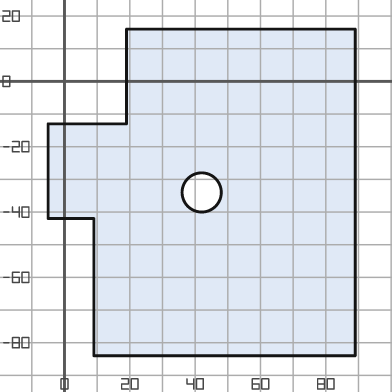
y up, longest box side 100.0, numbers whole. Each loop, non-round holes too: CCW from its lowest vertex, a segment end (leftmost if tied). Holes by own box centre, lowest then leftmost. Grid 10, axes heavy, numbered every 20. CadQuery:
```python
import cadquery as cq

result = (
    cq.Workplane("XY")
    .moveTo(9.0, -84.0)
    .lineTo(89.0, -84.0)
    .lineTo(89.0, 16.0)
    .lineTo(19.0, 16.0)
    .lineTo(19.0, -13.0)
    .lineTo(-5.0, -13.0)
    .lineTo(-5.0, -42.0)
    .lineTo(9.0, -42.0)
    .close()
    .moveTo(42.0, -34.0)
    .circle(6.0)
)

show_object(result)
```